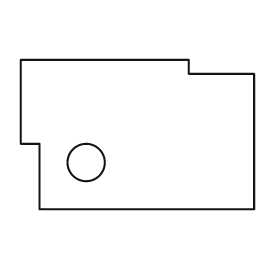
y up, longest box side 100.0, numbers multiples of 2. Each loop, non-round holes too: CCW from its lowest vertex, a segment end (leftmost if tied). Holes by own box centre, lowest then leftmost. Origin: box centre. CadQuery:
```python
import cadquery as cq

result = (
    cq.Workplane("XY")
    .moveTo(-42.0, -32.0)
    .lineTo(50.0, -32.0)
    .lineTo(50.0, 26.0)
    .lineTo(22.0, 26.0)
    .lineTo(22.0, 32.0)
    .lineTo(-50.0, 32.0)
    .lineTo(-50.0, -4.0)
    .lineTo(-42.0, -4.0)
    .close()
    .moveTo(-22.0, -12.0)
    .circle(8.0)
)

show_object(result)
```